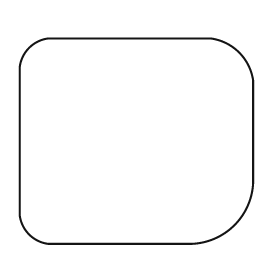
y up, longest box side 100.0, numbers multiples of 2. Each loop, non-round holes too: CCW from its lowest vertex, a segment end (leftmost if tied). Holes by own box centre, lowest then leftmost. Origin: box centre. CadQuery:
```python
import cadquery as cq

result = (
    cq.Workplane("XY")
    .moveTo(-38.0, -44.0)
    .lineTo(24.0, -44.0)
    .threePointArc((42.0, -36.0), (50.0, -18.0))
    .lineTo(50.0, 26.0)
    .threePointArc((44.0, 38.0), (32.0, 44.0))
    .lineTo(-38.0, 44.0)
    .threePointArc((-46.0, 40.0), (-50.0, 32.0))
    .lineTo(-50.0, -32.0)
    .threePointArc((-46.0, -40.0), (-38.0, -44.0))
    .close()
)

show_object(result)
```